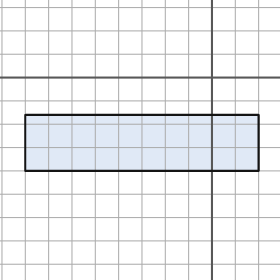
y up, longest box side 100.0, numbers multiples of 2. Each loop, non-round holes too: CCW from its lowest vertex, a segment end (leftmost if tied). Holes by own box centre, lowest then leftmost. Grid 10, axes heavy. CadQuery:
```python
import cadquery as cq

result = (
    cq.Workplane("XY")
    .moveTo(-80.0, -40.0)
    .lineTo(20.0, -40.0)
    .lineTo(20.0, -16.0)
    .lineTo(-80.0, -16.0)
    .close()
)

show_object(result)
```